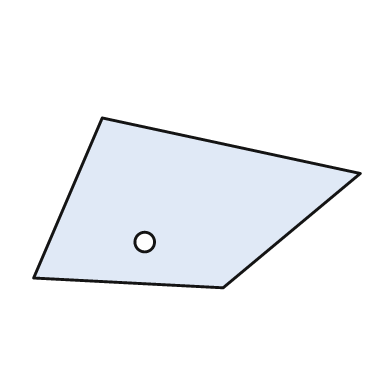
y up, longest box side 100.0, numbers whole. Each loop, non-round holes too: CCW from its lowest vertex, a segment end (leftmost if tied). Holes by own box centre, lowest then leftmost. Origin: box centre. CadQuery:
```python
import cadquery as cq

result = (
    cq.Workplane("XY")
    .moveTo(8.0, -26.0)
    .lineTo(50.0, 9.0)
    .lineTo(-29.0, 26.0)
    .lineTo(-50.0, -23.0)
    .close()
    .moveTo(-16.0, -12.0)
    .circle(3.0)
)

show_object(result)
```